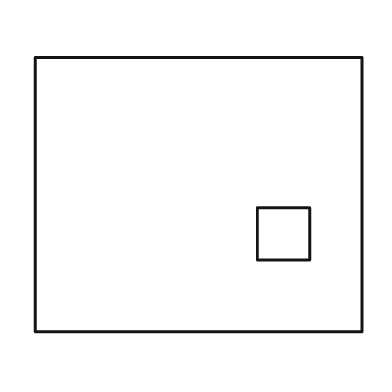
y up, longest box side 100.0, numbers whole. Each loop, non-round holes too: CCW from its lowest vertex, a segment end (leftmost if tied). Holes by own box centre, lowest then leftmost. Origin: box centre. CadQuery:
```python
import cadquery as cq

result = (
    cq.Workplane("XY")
    .moveTo(-50.0, -42.0)
    .lineTo(50.0, -42.0)
    .lineTo(50.0, 42.0)
    .lineTo(-50.0, 42.0)
    .close()
    .moveTo(18.0, -20.0)
    .lineTo(34.0, -20.0)
    .lineTo(34.0, -4.0)
    .lineTo(18.0, -4.0)
    .close()
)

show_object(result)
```